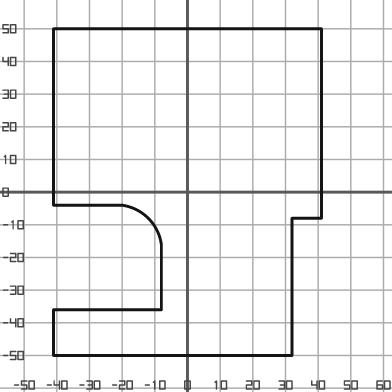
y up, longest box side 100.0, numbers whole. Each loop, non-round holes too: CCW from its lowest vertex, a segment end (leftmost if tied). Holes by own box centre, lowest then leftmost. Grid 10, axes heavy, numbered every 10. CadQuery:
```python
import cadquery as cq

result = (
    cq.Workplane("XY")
    .moveTo(-41.0, -50.0)
    .lineTo(32.0, -50.0)
    .lineTo(32.0, -8.0)
    .lineTo(41.0, -8.0)
    .lineTo(41.0, 50.0)
    .lineTo(-41.0, 50.0)
    .lineTo(-41.0, -4.0)
    .lineTo(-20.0, -4.0)
    .threePointArc((-12.0, -8.0), (-8.0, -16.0))
    .lineTo(-8.0, -36.0)
    .lineTo(-41.0, -36.0)
    .close()
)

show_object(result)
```